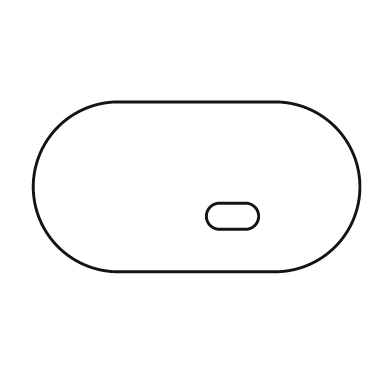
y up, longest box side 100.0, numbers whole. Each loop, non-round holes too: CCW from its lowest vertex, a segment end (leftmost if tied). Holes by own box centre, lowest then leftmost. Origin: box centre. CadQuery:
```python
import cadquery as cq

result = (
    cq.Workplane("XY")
    .moveTo(-24.0, -26.0)
    .lineTo(24.0, -26.0)
    .threePointArc((50.0, 0.0), (24.0, 26.0))
    .lineTo(-24.0, 26.0)
    .threePointArc((-50.0, 0.0), (-24.0, -26.0))
    .close()
    .moveTo(7.0, -13.0)
    .lineTo(15.0, -13.0)
    .threePointArc((19.0, -9.0), (15.0, -5.0))
    .lineTo(7.0, -5.0)
    .threePointArc((3.0, -9.0), (7.0, -13.0))
    .close()
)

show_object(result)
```